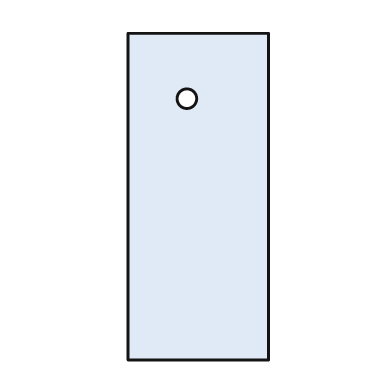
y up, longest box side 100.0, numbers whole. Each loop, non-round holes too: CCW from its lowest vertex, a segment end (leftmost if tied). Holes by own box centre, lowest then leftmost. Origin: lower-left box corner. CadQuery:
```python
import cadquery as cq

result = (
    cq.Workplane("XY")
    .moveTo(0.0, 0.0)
    .lineTo(43.0, 0.0)
    .lineTo(43.0, 100.0)
    .lineTo(0.0, 100.0)
    .close()
    .moveTo(18.0, 80.0)
    .circle(3.0)
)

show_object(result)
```